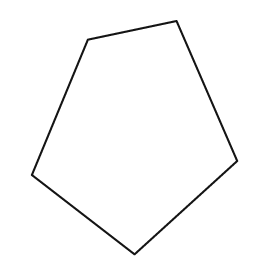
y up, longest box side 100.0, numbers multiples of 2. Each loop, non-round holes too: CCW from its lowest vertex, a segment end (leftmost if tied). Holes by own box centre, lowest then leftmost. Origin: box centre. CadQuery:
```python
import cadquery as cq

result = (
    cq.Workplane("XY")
    .moveTo(0.0, -50.0)
    .lineTo(44.0, -10.0)
    .lineTo(18.0, 50.0)
    .lineTo(-20.0, 42.0)
    .lineTo(-44.0, -16.0)
    .close()
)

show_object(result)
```